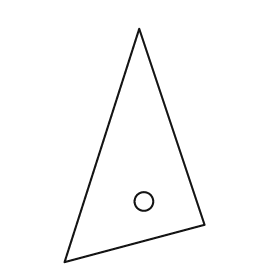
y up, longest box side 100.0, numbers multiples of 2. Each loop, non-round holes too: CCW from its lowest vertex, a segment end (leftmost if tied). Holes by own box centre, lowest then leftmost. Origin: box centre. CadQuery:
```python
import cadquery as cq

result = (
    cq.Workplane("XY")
    .moveTo(-30.0, -50.0)
    .lineTo(30.0, -34.0)
    .lineTo(2.0, 50.0)
    .close()
    .moveTo(4.0, -24.0)
    .circle(4.0)
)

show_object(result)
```